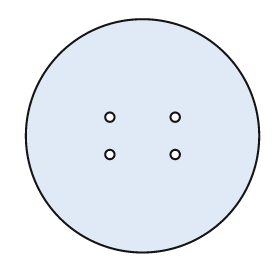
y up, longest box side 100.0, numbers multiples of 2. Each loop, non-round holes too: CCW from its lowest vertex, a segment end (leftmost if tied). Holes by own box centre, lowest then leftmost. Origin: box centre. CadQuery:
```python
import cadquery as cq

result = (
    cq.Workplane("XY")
    .moveTo(0.0, 0.0)
    .circle(50.0)
    .moveTo(-14.0, -8.0)
    .circle(2.0)
    .moveTo(14.0, -8.0)
    .circle(2.0)
    .moveTo(-14.0, 8.0)
    .circle(2.0)
    .moveTo(14.0, 8.0)
    .circle(2.0)
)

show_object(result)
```